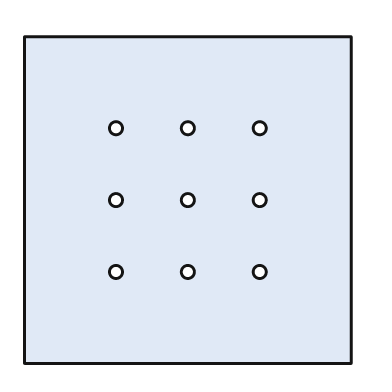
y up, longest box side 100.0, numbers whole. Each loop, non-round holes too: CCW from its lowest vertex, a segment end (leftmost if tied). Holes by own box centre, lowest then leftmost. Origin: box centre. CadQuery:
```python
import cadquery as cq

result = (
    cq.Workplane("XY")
    .moveTo(-50.0, -50.0)
    .lineTo(50.0, -50.0)
    .lineTo(50.0, 50.0)
    .lineTo(-50.0, 50.0)
    .close()
    .moveTo(-22.0, -22.0)
    .circle(2.0)
    .moveTo(0.0, -22.0)
    .circle(2.0)
    .moveTo(22.0, -22.0)
    .circle(2.0)
    .moveTo(-22.0, 0.0)
    .circle(2.0)
    .moveTo(0.0, 0.0)
    .circle(2.0)
    .moveTo(22.0, 0.0)
    .circle(2.0)
    .moveTo(-22.0, 22.0)
    .circle(2.0)
    .moveTo(0.0, 22.0)
    .circle(2.0)
    .moveTo(22.0, 22.0)
    .circle(2.0)
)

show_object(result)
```